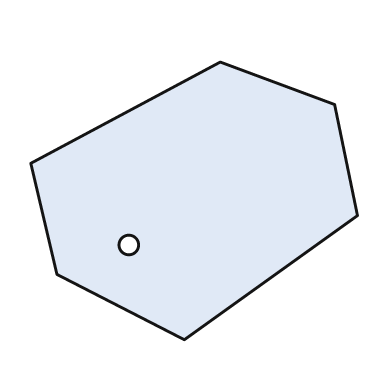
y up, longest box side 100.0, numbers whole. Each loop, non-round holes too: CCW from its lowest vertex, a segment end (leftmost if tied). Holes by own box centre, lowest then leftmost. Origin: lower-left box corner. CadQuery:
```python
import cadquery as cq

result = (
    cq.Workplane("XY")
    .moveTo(47.0, 0.0)
    .lineTo(100.0, 38.0)
    .lineTo(93.0, 72.0)
    .lineTo(58.0, 85.0)
    .lineTo(0.0, 54.0)
    .lineTo(8.0, 20.0)
    .close()
    .moveTo(30.0, 29.0)
    .circle(3.0)
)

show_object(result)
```